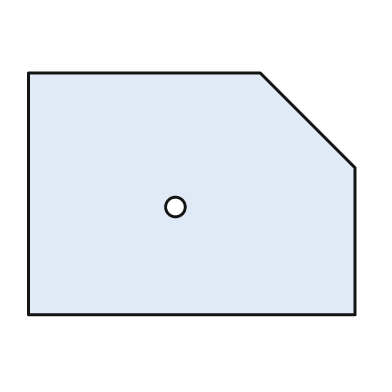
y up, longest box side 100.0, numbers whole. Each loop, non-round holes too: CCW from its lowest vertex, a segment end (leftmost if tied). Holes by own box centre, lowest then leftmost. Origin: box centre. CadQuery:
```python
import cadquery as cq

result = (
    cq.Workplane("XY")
    .moveTo(-50.0, -37.0)
    .lineTo(50.0, -37.0)
    .lineTo(50.0, 8.0)
    .lineTo(21.0, 37.0)
    .lineTo(-50.0, 37.0)
    .close()
    .moveTo(-5.0, -4.0)
    .circle(3.0)
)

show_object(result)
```